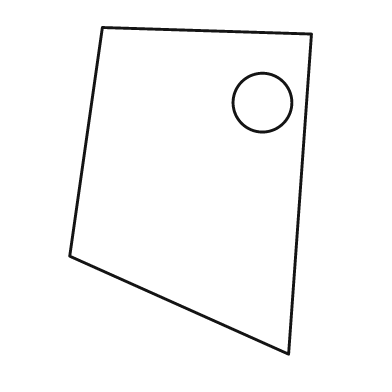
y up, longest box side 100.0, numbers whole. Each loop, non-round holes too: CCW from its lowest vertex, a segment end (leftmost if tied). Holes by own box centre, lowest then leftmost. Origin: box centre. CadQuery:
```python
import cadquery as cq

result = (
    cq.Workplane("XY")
    .moveTo(30.0, -50.0)
    .lineTo(37.0, 48.0)
    .lineTo(-27.0, 50.0)
    .lineTo(-37.0, -20.0)
    .close()
    .moveTo(22.0, 27.0)
    .circle(9.0)
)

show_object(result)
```